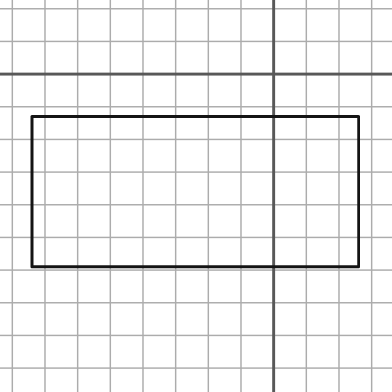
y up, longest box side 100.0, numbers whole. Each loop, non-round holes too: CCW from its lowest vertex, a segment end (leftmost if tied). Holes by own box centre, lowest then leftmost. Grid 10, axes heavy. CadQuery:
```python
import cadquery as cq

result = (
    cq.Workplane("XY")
    .moveTo(-74.0, -59.0)
    .lineTo(26.0, -59.0)
    .lineTo(26.0, -13.0)
    .lineTo(-74.0, -13.0)
    .close()
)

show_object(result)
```